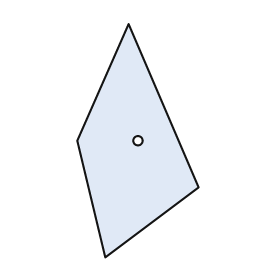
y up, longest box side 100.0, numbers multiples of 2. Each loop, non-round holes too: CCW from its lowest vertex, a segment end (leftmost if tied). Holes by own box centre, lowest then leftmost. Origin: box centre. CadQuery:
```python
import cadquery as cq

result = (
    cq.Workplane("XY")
    .moveTo(-14.0, -50.0)
    .lineTo(26.0, -20.0)
    .lineTo(-4.0, 50.0)
    .lineTo(-26.0, 0.0)
    .close()
    .moveTo(0.0, 0.0)
    .circle(2.0)
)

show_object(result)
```